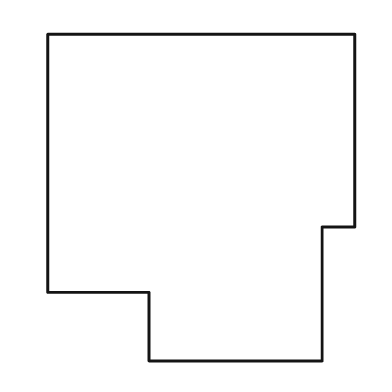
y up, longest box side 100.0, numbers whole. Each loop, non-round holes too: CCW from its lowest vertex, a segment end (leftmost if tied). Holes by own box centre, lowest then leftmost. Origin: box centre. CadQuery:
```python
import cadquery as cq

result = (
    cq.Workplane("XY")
    .moveTo(-16.0, -50.0)
    .lineTo(37.0, -50.0)
    .lineTo(37.0, -9.0)
    .lineTo(47.0, -9.0)
    .lineTo(47.0, 50.0)
    .lineTo(-47.0, 50.0)
    .lineTo(-47.0, -29.0)
    .lineTo(-16.0, -29.0)
    .close()
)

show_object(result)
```